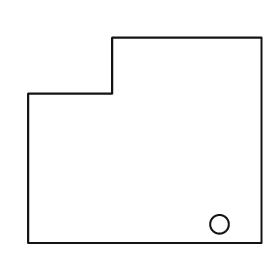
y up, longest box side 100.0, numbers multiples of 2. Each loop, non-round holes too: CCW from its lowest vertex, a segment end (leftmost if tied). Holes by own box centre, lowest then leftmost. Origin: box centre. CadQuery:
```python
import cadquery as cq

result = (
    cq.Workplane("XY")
    .moveTo(-50.0, -44.0)
    .lineTo(50.0, -44.0)
    .lineTo(50.0, 44.0)
    .lineTo(-14.0, 44.0)
    .lineTo(-14.0, 20.0)
    .lineTo(-50.0, 20.0)
    .close()
    .moveTo(32.0, -36.0)
    .circle(4.0)
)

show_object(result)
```